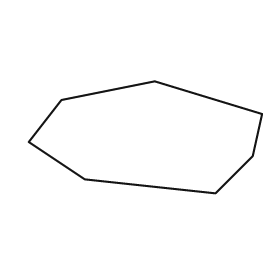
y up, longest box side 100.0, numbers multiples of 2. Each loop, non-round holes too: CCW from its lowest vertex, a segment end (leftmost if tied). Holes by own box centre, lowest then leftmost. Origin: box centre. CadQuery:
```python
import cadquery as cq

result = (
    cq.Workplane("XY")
    .moveTo(30.0, -24.0)
    .lineTo(46.0, -8.0)
    .lineTo(50.0, 10.0)
    .lineTo(4.0, 24.0)
    .lineTo(-36.0, 16.0)
    .lineTo(-50.0, -2.0)
    .lineTo(-26.0, -18.0)
    .close()
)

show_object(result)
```